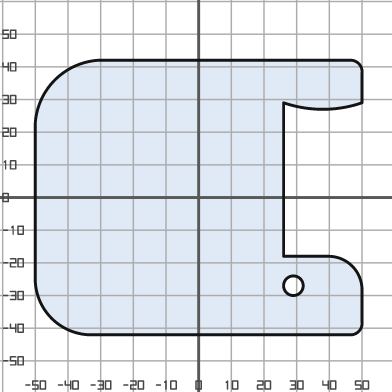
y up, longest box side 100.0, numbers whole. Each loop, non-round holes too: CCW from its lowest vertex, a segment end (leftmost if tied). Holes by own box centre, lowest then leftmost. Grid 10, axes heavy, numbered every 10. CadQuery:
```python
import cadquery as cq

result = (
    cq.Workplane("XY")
    .moveTo(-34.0, -42.0)
    .lineTo(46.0, -42.0)
    .threePointArc((49.0, -41.0), (50.0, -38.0))
    .lineTo(50.0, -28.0)
    .threePointArc((47.0, -21.0), (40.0, -18.0))
    .lineTo(26.0, -18.0)
    .lineTo(26.0, 29.0)
    .threePointArc((38.0, 27.0), (50.0, 29.0))
    .lineTo(50.0, 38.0)
    .threePointArc((49.0, 41.0), (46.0, 42.0))
    .lineTo(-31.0, 42.0)
    .threePointArc((-44.0, 36.0), (-50.0, 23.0))
    .lineTo(-50.0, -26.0)
    .threePointArc((-45.0, -37.0), (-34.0, -42.0))
    .close()
    .moveTo(29.0, -27.0)
    .circle(3.0)
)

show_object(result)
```